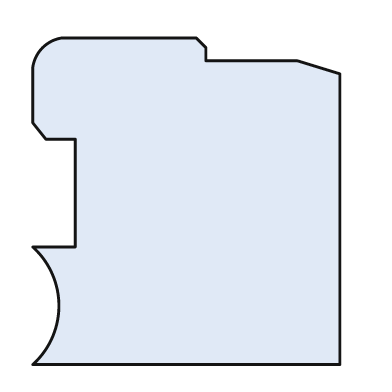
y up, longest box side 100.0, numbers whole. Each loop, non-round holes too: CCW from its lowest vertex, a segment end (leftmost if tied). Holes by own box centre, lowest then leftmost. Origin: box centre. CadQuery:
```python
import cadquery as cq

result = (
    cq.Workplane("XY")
    .moveTo(-47.0, -50.0)
    .lineTo(47.0, -50.0)
    .lineTo(47.0, 39.0)
    .lineTo(34.0, 43.0)
    .lineTo(6.0, 43.0)
    .lineTo(6.0, 47.0)
    .lineTo(3.0, 50.0)
    .lineTo(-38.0, 50.0)
    .threePointArc((-44.0, 47.0), (-47.0, 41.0))
    .lineTo(-47.0, 24.0)
    .lineTo(-43.0, 19.0)
    .lineTo(-34.0, 19.0)
    .lineTo(-34.0, -14.0)
    .lineTo(-47.0, -14.0)
    .threePointArc((-39.0, -32.0), (-47.0, -50.0))
    .close()
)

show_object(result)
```